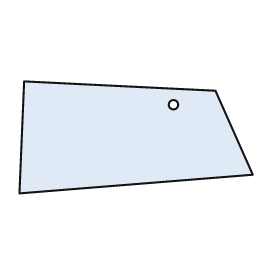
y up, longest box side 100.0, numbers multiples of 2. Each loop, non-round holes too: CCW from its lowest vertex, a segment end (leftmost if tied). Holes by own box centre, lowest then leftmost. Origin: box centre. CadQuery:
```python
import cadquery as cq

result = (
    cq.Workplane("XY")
    .moveTo(-50.0, -24.0)
    .lineTo(50.0, -16.0)
    .lineTo(34.0, 20.0)
    .lineTo(-48.0, 24.0)
    .close()
    .moveTo(16.0, 14.0)
    .circle(2.0)
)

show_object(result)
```